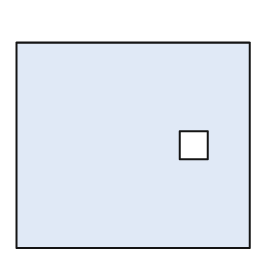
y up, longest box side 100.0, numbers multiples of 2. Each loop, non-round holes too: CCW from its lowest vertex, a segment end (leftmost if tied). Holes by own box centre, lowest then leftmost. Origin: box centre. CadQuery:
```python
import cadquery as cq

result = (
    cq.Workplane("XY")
    .moveTo(-50.0, -44.0)
    .lineTo(50.0, -44.0)
    .lineTo(50.0, 44.0)
    .lineTo(-50.0, 44.0)
    .close()
    .moveTo(20.0, -6.0)
    .lineTo(32.0, -6.0)
    .lineTo(32.0, 6.0)
    .lineTo(20.0, 6.0)
    .close()
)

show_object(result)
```